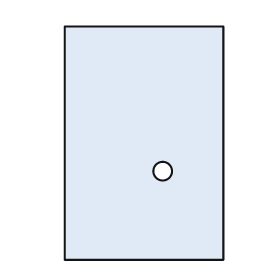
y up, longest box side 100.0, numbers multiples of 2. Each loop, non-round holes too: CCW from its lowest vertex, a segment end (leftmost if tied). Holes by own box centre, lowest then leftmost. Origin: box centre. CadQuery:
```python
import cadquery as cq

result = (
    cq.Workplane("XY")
    .moveTo(-34.0, -50.0)
    .lineTo(34.0, -50.0)
    .lineTo(34.0, 50.0)
    .lineTo(-34.0, 50.0)
    .close()
    .moveTo(8.0, -12.0)
    .circle(4.0)
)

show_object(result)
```